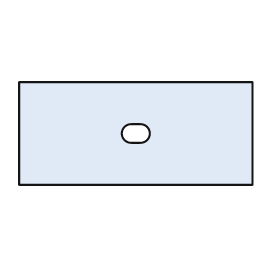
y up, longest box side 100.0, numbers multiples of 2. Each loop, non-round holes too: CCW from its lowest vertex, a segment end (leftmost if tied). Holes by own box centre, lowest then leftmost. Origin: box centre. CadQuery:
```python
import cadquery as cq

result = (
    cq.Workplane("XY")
    .moveTo(-50.0, -22.0)
    .lineTo(50.0, -22.0)
    .lineTo(50.0, 22.0)
    .lineTo(-50.0, 22.0)
    .close()
    .moveTo(-2.0, -4.0)
    .lineTo(2.0, -4.0)
    .threePointArc((6.0, 0.0), (2.0, 4.0))
    .lineTo(-2.0, 4.0)
    .threePointArc((-6.0, 0.0), (-2.0, -4.0))
    .close()
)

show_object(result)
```